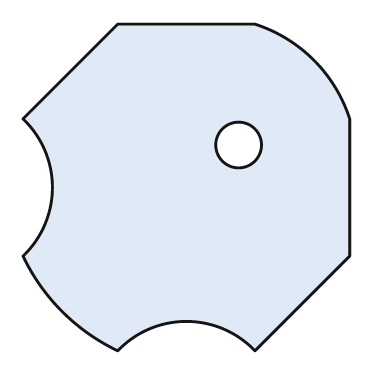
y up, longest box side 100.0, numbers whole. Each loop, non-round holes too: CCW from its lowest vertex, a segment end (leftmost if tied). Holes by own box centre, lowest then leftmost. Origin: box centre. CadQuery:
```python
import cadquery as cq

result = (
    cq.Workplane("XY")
    .moveTo(-21.0, -50.0)
    .threePointArc((0.0, -41.0), (21.0, -50.0))
    .lineTo(50.0, -21.0)
    .lineTo(50.0, 21.0)
    .threePointArc((39.0, 39.0), (21.0, 50.0))
    .lineTo(-21.0, 50.0)
    .lineTo(-50.0, 21.0)
    .threePointArc((-41.0, 0.0), (-50.0, -21.0))
    .threePointArc((-38.0, -38.0), (-21.0, -50.0))
    .close()
    .moveTo(16.0, 13.0)
    .circle(7.0)
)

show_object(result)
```